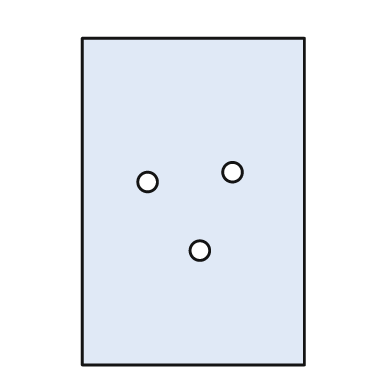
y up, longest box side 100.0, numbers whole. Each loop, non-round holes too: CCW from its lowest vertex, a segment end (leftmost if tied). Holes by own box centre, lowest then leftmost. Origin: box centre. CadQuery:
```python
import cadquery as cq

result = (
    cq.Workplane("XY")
    .moveTo(-34.0, -50.0)
    .lineTo(34.0, -50.0)
    .lineTo(34.0, 50.0)
    .lineTo(-34.0, 50.0)
    .close()
    .moveTo(2.0, -15.0)
    .circle(3.0)
    .moveTo(-14.0, 6.0)
    .circle(3.0)
    .moveTo(12.0, 9.0)
    .circle(3.0)
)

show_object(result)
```